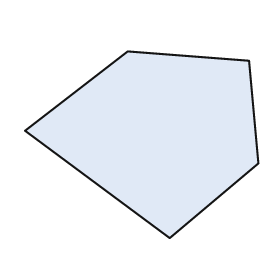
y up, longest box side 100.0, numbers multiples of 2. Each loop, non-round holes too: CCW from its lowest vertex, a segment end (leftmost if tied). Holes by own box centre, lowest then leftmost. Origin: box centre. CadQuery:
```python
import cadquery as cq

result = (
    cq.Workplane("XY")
    .moveTo(12.0, -40.0)
    .lineTo(50.0, -8.0)
    .lineTo(46.0, 36.0)
    .lineTo(-6.0, 40.0)
    .lineTo(-50.0, 6.0)
    .close()
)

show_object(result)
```